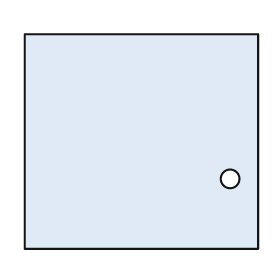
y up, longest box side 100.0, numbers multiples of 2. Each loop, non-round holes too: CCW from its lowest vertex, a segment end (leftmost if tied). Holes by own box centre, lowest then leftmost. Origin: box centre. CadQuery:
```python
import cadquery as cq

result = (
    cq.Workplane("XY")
    .moveTo(-50.0, -46.0)
    .lineTo(50.0, -46.0)
    .lineTo(50.0, 46.0)
    .lineTo(-50.0, 46.0)
    .close()
    .moveTo(38.0, -16.0)
    .circle(4.0)
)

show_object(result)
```